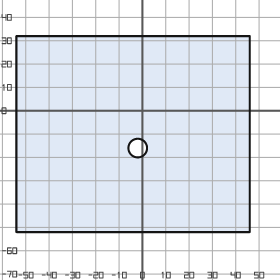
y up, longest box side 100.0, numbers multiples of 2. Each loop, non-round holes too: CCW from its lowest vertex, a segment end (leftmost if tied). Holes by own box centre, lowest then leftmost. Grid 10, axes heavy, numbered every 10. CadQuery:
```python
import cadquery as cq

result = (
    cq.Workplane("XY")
    .moveTo(-54.0, -52.0)
    .lineTo(46.0, -52.0)
    .lineTo(46.0, 32.0)
    .lineTo(-54.0, 32.0)
    .close()
    .moveTo(-2.0, -16.0)
    .circle(4.0)
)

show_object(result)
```